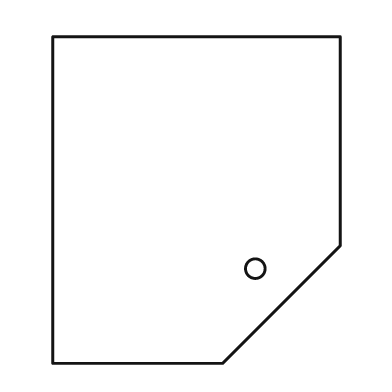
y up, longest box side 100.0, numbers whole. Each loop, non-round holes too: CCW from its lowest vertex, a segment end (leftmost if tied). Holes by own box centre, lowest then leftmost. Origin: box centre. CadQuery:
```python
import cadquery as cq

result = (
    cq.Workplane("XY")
    .moveTo(-44.0, -50.0)
    .lineTo(8.0, -50.0)
    .lineTo(44.0, -14.0)
    .lineTo(44.0, 50.0)
    .lineTo(-44.0, 50.0)
    .close()
    .moveTo(18.0, -21.0)
    .circle(3.0)
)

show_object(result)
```